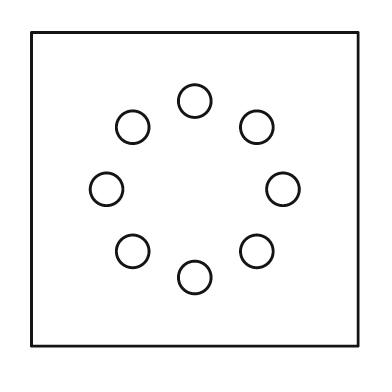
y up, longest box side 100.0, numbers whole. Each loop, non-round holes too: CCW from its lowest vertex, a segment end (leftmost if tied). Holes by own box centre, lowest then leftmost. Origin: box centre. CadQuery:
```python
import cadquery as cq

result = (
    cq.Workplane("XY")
    .moveTo(-50.0, -48.0)
    .lineTo(50.0, -48.0)
    .lineTo(50.0, 48.0)
    .lineTo(-50.0, 48.0)
    .close()
    .moveTo(0.0, -27.0)
    .circle(5.0)
    .moveTo(-19.0, -19.0)
    .circle(5.0)
    .moveTo(19.0, -19.0)
    .circle(5.0)
    .moveTo(-27.0, 0.0)
    .circle(5.0)
    .moveTo(27.0, 0.0)
    .circle(5.0)
    .moveTo(-19.0, 19.0)
    .circle(5.0)
    .moveTo(19.0, 19.0)
    .circle(5.0)
    .moveTo(0.0, 27.0)
    .circle(5.0)
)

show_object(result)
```